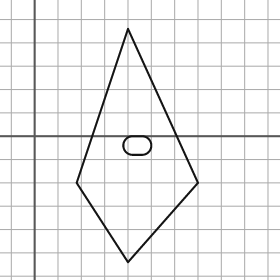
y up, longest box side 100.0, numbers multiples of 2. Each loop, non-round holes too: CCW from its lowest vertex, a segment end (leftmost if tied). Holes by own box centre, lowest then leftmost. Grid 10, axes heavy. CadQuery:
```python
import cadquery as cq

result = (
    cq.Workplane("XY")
    .moveTo(40.0, -54.0)
    .lineTo(70.0, -20.0)
    .lineTo(40.0, 46.0)
    .lineTo(18.0, -20.0)
    .close()
    .moveTo(42.0, -8.0)
    .lineTo(46.0, -8.0)
    .threePointArc((50.0, -4.0), (46.0, 0.0))
    .lineTo(42.0, 0.0)
    .threePointArc((38.0, -4.0), (42.0, -8.0))
    .close()
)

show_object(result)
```